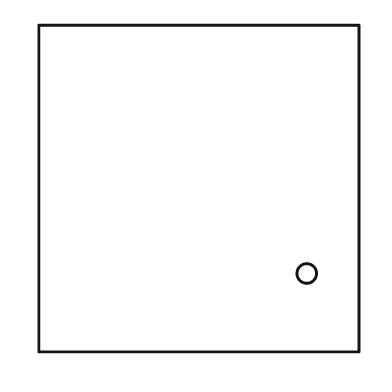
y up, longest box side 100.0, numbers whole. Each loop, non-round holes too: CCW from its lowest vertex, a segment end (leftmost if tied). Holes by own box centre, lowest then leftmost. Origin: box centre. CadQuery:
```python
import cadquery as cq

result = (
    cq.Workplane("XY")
    .moveTo(-49.0, -50.0)
    .lineTo(49.0, -50.0)
    .lineTo(49.0, 50.0)
    .lineTo(-49.0, 50.0)
    .close()
    .moveTo(33.0, -26.0)
    .circle(3.0)
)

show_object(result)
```